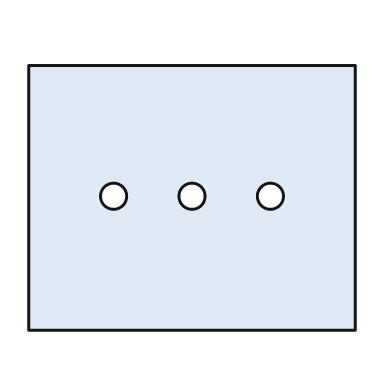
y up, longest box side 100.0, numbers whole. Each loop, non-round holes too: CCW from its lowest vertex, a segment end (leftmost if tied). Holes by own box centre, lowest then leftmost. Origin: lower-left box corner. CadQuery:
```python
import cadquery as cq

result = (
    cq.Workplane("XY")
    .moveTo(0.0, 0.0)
    .lineTo(100.0, 0.0)
    .lineTo(100.0, 81.0)
    .lineTo(0.0, 81.0)
    .close()
    .moveTo(26.0, 41.0)
    .circle(4.0)
    .moveTo(50.0, 41.0)
    .circle(4.0)
    .moveTo(74.0, 41.0)
    .circle(4.0)
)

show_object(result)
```